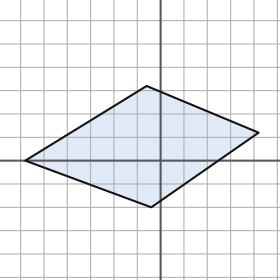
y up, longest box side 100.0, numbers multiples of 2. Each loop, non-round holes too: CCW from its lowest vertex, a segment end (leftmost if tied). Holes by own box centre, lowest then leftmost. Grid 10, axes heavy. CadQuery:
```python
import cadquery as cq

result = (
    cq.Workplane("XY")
    .moveTo(-4.0, -20.0)
    .lineTo(42.0, 12.0)
    .lineTo(-6.0, 32.0)
    .lineTo(-58.0, 0.0)
    .close()
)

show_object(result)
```